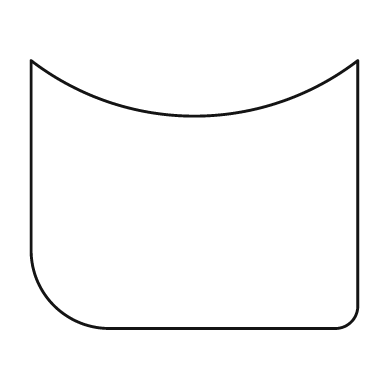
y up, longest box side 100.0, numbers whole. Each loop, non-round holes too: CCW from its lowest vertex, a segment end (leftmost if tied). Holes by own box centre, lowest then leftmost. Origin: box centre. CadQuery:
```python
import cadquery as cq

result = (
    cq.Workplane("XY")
    .moveTo(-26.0, -41.0)
    .lineTo(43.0, -41.0)
    .threePointArc((48.0, -39.0), (50.0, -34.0))
    .lineTo(50.0, 41.0)
    .threePointArc((0.0, 24.0), (-50.0, 41.0))
    .lineTo(-50.0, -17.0)
    .threePointArc((-43.0, -34.0), (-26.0, -41.0))
    .close()
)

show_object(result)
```